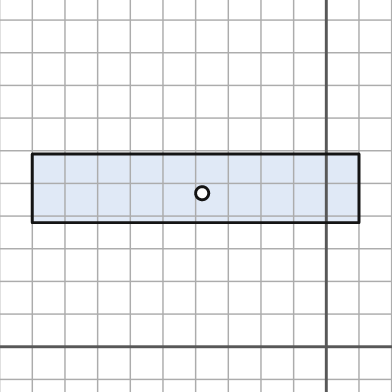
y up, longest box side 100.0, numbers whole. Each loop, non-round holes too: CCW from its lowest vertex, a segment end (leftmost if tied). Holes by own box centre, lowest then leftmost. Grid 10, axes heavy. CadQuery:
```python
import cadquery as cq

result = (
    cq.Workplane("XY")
    .moveTo(-90.0, 38.0)
    .lineTo(10.0, 38.0)
    .lineTo(10.0, 59.0)
    .lineTo(-90.0, 59.0)
    .close()
    .moveTo(-38.0, 47.0)
    .circle(2.0)
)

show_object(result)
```